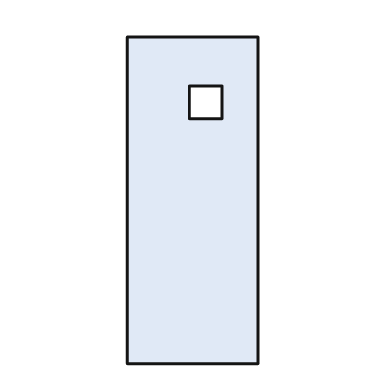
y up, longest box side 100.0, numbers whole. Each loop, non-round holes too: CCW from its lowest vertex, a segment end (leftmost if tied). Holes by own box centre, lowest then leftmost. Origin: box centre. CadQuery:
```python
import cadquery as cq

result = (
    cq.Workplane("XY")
    .moveTo(-20.0, -50.0)
    .lineTo(20.0, -50.0)
    .lineTo(20.0, 50.0)
    .lineTo(-20.0, 50.0)
    .close()
    .moveTo(-1.0, 25.0)
    .lineTo(9.0, 25.0)
    .lineTo(9.0, 35.0)
    .lineTo(-1.0, 35.0)
    .close()
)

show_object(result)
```